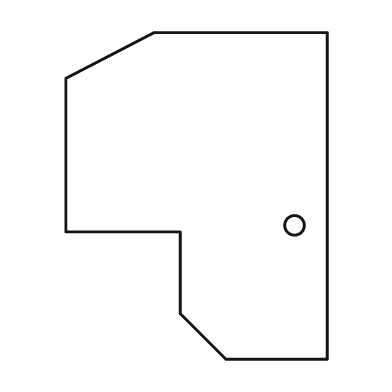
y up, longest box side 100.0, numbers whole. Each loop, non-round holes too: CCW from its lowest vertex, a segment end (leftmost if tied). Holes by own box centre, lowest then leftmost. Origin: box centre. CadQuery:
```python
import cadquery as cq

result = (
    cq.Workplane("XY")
    .moveTo(9.0, -50.0)
    .lineTo(40.0, -50.0)
    .lineTo(40.0, 50.0)
    .lineTo(-13.0, 50.0)
    .lineTo(-40.0, 36.0)
    .lineTo(-40.0, -11.0)
    .lineTo(-5.0, -11.0)
    .lineTo(-5.0, -36.0)
    .close()
    .moveTo(30.0, -9.0)
    .circle(3.0)
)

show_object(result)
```